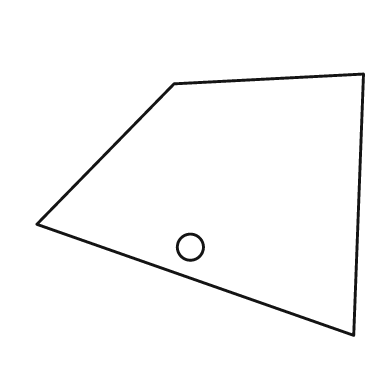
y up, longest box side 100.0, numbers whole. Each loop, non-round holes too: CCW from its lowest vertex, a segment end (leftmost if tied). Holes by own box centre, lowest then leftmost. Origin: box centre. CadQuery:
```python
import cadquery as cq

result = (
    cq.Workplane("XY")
    .moveTo(47.0, -40.0)
    .lineTo(50.0, 40.0)
    .lineTo(-8.0, 37.0)
    .lineTo(-50.0, -6.0)
    .close()
    .moveTo(-3.0, -13.0)
    .circle(4.0)
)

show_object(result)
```